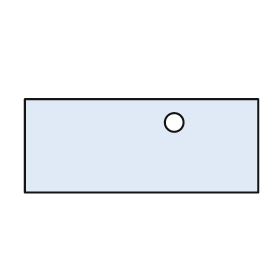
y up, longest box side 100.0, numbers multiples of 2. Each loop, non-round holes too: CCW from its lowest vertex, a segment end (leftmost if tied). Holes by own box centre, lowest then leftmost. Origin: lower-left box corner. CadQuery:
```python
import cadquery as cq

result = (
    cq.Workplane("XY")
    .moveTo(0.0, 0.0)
    .lineTo(100.0, 0.0)
    .lineTo(100.0, 40.0)
    .lineTo(0.0, 40.0)
    .close()
    .moveTo(64.0, 30.0)
    .circle(4.0)
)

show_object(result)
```